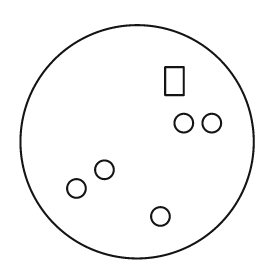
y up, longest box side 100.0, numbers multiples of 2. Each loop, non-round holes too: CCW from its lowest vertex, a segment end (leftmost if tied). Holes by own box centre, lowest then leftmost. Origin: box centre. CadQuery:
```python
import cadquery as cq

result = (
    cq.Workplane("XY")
    .moveTo(0.0, 0.0)
    .circle(50.0)
    .moveTo(10.0, -32.0)
    .circle(4.0)
    .moveTo(-26.0, -20.0)
    .circle(4.0)
    .moveTo(-14.0, -12.0)
    .circle(4.0)
    .moveTo(20.0, 8.0)
    .circle(4.0)
    .moveTo(32.0, 8.0)
    .circle(4.0)
    .moveTo(12.0, 20.0)
    .lineTo(20.0, 20.0)
    .lineTo(20.0, 32.0)
    .lineTo(12.0, 32.0)
    .close()
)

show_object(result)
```